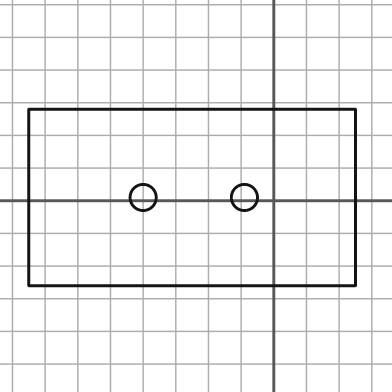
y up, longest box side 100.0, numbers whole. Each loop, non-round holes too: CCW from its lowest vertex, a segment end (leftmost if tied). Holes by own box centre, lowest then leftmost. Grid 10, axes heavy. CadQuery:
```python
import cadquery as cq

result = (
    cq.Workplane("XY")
    .moveTo(-75.0, -26.0)
    .lineTo(25.0, -26.0)
    .lineTo(25.0, 28.0)
    .lineTo(-75.0, 28.0)
    .close()
    .moveTo(-40.0, 1.0)
    .circle(4.0)
    .moveTo(-9.0, 1.0)
    .circle(4.0)
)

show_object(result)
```